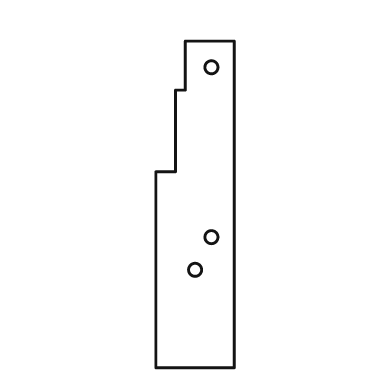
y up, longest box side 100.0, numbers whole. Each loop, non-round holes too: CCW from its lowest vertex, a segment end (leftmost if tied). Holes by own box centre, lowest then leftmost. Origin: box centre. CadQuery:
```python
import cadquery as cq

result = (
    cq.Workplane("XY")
    .moveTo(-12.0, -50.0)
    .lineTo(12.0, -50.0)
    .lineTo(12.0, 50.0)
    .lineTo(-3.0, 50.0)
    .lineTo(-3.0, 35.0)
    .lineTo(-6.0, 35.0)
    .lineTo(-6.0, 10.0)
    .lineTo(-12.0, 10.0)
    .close()
    .moveTo(0.0, -20.0)
    .circle(2.0)
    .moveTo(5.0, -10.0)
    .circle(2.0)
    .moveTo(5.0, 42.0)
    .circle(2.0)
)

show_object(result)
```